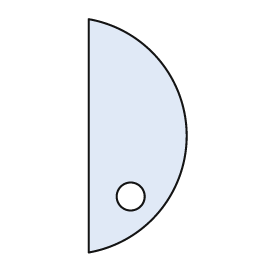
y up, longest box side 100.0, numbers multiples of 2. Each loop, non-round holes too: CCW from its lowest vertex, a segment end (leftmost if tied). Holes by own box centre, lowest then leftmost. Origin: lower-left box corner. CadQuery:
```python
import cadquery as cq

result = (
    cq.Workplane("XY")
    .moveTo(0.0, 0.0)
    .threePointArc((42.0, 50.0), (0.0, 100.0))
    .close()
    .moveTo(18.0, 24.0)
    .circle(6.0)
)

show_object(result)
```